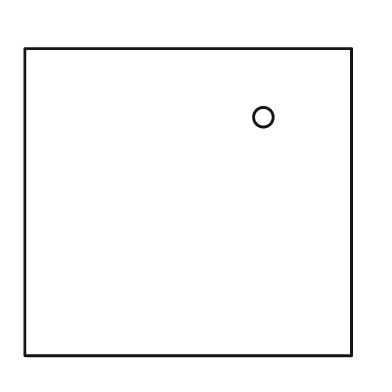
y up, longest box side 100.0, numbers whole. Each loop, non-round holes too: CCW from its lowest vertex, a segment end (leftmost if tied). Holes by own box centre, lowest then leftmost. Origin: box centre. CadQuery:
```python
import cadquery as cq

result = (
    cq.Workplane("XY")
    .moveTo(-50.0, -47.0)
    .lineTo(50.0, -47.0)
    .lineTo(50.0, 47.0)
    .lineTo(-50.0, 47.0)
    .close()
    .moveTo(23.0, 26.0)
    .circle(3.0)
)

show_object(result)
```